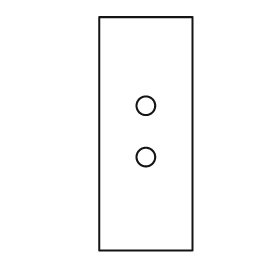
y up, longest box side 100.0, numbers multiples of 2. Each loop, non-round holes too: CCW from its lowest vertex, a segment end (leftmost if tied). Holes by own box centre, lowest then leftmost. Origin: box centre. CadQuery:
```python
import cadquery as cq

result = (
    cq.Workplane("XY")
    .moveTo(-20.0, -50.0)
    .lineTo(20.0, -50.0)
    .lineTo(20.0, 50.0)
    .lineTo(-20.0, 50.0)
    .close()
    .moveTo(0.0, -10.0)
    .circle(4.0)
    .moveTo(0.0, 12.0)
    .circle(4.0)
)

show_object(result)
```